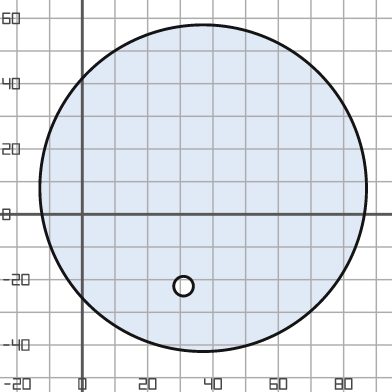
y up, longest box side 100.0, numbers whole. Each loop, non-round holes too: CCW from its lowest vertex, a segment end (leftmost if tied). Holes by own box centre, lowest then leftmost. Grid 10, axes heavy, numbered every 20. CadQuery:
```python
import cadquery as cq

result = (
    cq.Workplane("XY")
    .moveTo(37.0, 8.0)
    .circle(50.0)
    .moveTo(31.0, -22.0)
    .circle(3.0)
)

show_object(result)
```